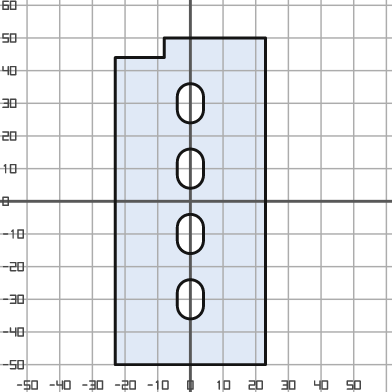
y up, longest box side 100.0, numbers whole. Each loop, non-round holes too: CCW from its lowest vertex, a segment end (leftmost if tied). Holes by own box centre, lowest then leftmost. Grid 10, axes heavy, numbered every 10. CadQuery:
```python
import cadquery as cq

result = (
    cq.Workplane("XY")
    .moveTo(-23.0, -50.0)
    .lineTo(23.0, -50.0)
    .lineTo(23.0, 50.0)
    .lineTo(-8.0, 50.0)
    .lineTo(-8.0, 44.0)
    .lineTo(-23.0, 44.0)
    .close()
    .moveTo(-4.0, -32.0)
    .threePointArc((0.0, -36.0), (4.0, -32.0))
    .lineTo(4.0, -28.0)
    .threePointArc((0.0, -24.0), (-4.0, -28.0))
    .close()
    .moveTo(-4.0, -12.0)
    .threePointArc((0.0, -16.0), (4.0, -12.0))
    .lineTo(4.0, -8.0)
    .threePointArc((0.0, -4.0), (-4.0, -8.0))
    .close()
    .moveTo(-4.0, 8.0)
    .threePointArc((0.0, 4.0), (4.0, 8.0))
    .lineTo(4.0, 12.0)
    .threePointArc((0.0, 16.0), (-4.0, 12.0))
    .close()
    .moveTo(-4.0, 28.0)
    .threePointArc((0.0, 24.0), (4.0, 28.0))
    .lineTo(4.0, 32.0)
    .threePointArc((0.0, 36.0), (-4.0, 32.0))
    .close()
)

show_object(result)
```